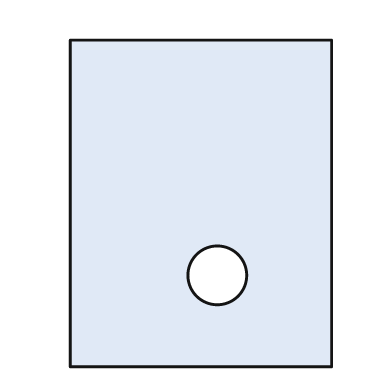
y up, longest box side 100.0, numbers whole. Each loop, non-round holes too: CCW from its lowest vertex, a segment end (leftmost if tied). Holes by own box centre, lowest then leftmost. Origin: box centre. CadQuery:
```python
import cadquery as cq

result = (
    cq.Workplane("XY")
    .moveTo(-40.0, -50.0)
    .lineTo(40.0, -50.0)
    .lineTo(40.0, 50.0)
    .lineTo(-40.0, 50.0)
    .close()
    .moveTo(5.0, -22.0)
    .circle(9.0)
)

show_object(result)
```